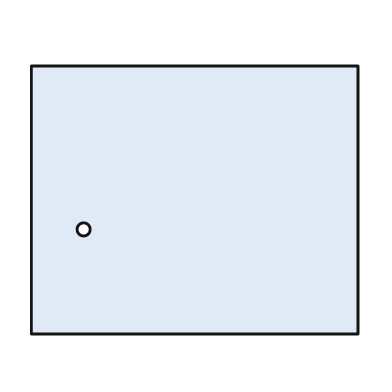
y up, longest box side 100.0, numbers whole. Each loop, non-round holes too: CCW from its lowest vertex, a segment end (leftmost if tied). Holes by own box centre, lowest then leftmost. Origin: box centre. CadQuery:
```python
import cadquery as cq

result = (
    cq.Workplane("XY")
    .moveTo(-50.0, -41.0)
    .lineTo(50.0, -41.0)
    .lineTo(50.0, 41.0)
    .lineTo(-50.0, 41.0)
    .close()
    .moveTo(-34.0, -9.0)
    .circle(2.0)
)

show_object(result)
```